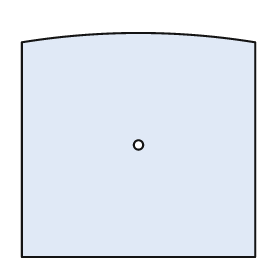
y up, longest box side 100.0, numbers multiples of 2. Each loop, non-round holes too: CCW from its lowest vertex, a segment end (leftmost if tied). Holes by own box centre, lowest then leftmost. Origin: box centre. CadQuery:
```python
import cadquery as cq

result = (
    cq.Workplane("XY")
    .moveTo(-50.0, -48.0)
    .lineTo(50.0, -48.0)
    .lineTo(50.0, 44.0)
    .threePointArc((0.0, 48.0), (-50.0, 44.0))
    .close()
    .moveTo(0.0, 0.0)
    .circle(2.0)
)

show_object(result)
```